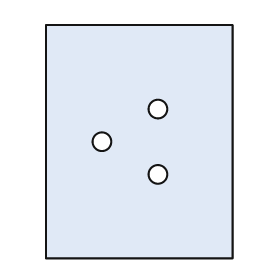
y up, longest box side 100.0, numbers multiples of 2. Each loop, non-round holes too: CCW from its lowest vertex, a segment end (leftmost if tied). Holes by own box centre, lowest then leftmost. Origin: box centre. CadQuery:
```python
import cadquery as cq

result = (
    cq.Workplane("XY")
    .moveTo(-40.0, -50.0)
    .lineTo(40.0, -50.0)
    .lineTo(40.0, 50.0)
    .lineTo(-40.0, 50.0)
    .close()
    .moveTo(8.0, -14.0)
    .circle(4.0)
    .moveTo(-16.0, 0.0)
    .circle(4.0)
    .moveTo(8.0, 14.0)
    .circle(4.0)
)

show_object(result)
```